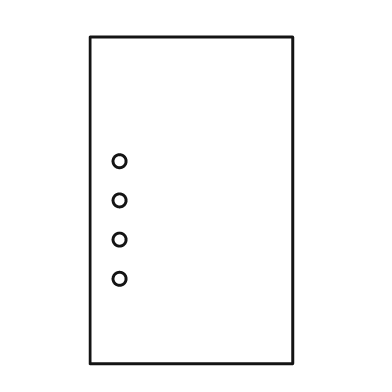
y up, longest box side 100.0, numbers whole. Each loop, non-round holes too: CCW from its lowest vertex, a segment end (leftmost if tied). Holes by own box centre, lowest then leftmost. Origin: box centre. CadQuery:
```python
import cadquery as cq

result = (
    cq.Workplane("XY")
    .moveTo(-31.0, -50.0)
    .lineTo(31.0, -50.0)
    .lineTo(31.0, 50.0)
    .lineTo(-31.0, 50.0)
    .close()
    .moveTo(-22.0, -24.0)
    .circle(2.0)
    .moveTo(-22.0, -12.0)
    .circle(2.0)
    .moveTo(-22.0, 0.0)
    .circle(2.0)
    .moveTo(-22.0, 12.0)
    .circle(2.0)
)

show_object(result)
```